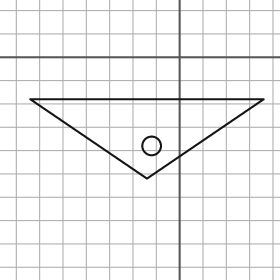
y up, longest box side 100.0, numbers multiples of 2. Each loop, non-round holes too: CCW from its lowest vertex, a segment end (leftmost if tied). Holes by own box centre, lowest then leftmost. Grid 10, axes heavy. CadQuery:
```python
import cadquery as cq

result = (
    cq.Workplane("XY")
    .moveTo(-14.0, -52.0)
    .lineTo(36.0, -18.0)
    .lineTo(-64.0, -18.0)
    .close()
    .moveTo(-12.0, -38.0)
    .circle(4.0)
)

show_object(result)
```